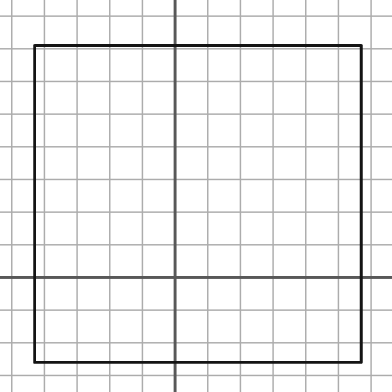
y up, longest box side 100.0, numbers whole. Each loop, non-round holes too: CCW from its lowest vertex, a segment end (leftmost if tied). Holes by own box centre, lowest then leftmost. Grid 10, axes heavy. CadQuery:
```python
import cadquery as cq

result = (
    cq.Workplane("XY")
    .moveTo(-43.0, -26.0)
    .lineTo(57.0, -26.0)
    .lineTo(57.0, 71.0)
    .lineTo(-43.0, 71.0)
    .close()
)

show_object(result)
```